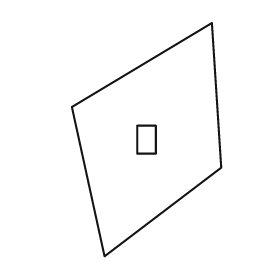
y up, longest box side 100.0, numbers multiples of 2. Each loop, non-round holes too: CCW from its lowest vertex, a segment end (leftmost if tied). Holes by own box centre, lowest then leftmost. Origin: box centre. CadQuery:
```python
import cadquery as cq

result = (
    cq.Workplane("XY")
    .moveTo(-18.0, -50.0)
    .lineTo(32.0, -12.0)
    .lineTo(28.0, 50.0)
    .lineTo(-32.0, 14.0)
    .close()
    .moveTo(-4.0, -6.0)
    .lineTo(4.0, -6.0)
    .lineTo(4.0, 6.0)
    .lineTo(-4.0, 6.0)
    .close()
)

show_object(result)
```